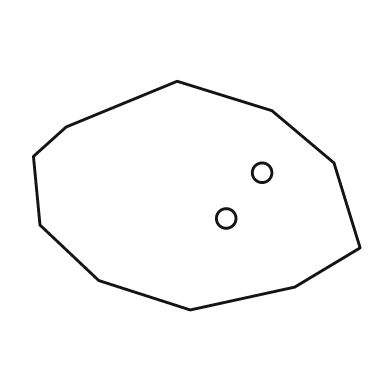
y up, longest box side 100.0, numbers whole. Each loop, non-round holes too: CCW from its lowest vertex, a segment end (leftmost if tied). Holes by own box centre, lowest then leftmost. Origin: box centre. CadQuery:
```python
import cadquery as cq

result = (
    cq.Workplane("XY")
    .moveTo(-2.0, -35.0)
    .lineTo(30.0, -28.0)
    .lineTo(50.0, -16.0)
    .lineTo(42.0, 10.0)
    .lineTo(23.0, 26.0)
    .lineTo(-6.0, 35.0)
    .lineTo(-40.0, 21.0)
    .lineTo(-50.0, 12.0)
    .lineTo(-48.0, -9.0)
    .lineTo(-30.0, -26.0)
    .close()
    .moveTo(9.0, -7.0)
    .circle(3.0)
    .moveTo(20.0, 7.0)
    .circle(3.0)
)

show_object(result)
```